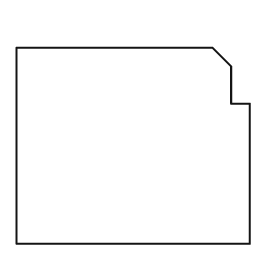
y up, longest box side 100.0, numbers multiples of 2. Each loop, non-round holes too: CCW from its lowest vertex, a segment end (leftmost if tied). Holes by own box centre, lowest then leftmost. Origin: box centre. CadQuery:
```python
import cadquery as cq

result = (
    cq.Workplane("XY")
    .moveTo(-50.0, -42.0)
    .lineTo(50.0, -42.0)
    .lineTo(50.0, 18.0)
    .lineTo(42.0, 18.0)
    .lineTo(42.0, 34.0)
    .lineTo(34.0, 42.0)
    .lineTo(-50.0, 42.0)
    .close()
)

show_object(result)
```